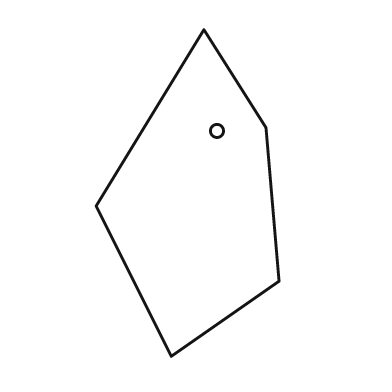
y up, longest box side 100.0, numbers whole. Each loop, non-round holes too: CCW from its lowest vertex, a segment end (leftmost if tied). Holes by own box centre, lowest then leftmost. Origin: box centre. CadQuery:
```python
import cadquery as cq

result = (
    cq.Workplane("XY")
    .moveTo(-5.0, -50.0)
    .lineTo(28.0, -27.0)
    .lineTo(24.0, 20.0)
    .lineTo(5.0, 50.0)
    .lineTo(-28.0, -4.0)
    .close()
    .moveTo(9.0, 19.0)
    .circle(2.0)
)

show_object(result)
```